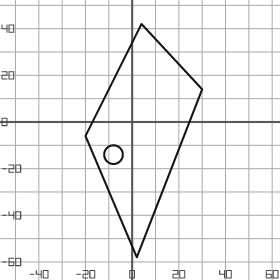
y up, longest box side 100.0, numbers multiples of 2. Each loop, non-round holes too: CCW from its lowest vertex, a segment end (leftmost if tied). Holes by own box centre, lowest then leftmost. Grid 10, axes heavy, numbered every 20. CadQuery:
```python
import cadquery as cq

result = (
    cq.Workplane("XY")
    .moveTo(2.0, -58.0)
    .lineTo(30.0, 14.0)
    .lineTo(4.0, 42.0)
    .lineTo(-20.0, -6.0)
    .close()
    .moveTo(-8.0, -14.0)
    .circle(4.0)
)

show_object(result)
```